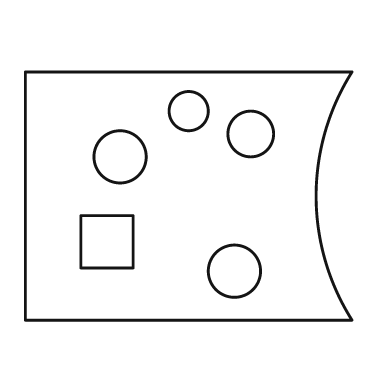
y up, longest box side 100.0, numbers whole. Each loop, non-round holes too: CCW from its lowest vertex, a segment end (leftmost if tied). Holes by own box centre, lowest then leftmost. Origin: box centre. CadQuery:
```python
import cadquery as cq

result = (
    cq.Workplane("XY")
    .moveTo(-50.0, -38.0)
    .lineTo(50.0, -38.0)
    .threePointArc((39.0, 0.0), (50.0, 38.0))
    .lineTo(-50.0, 38.0)
    .close()
    .moveTo(14.0, -23.0)
    .circle(8.0)
    .moveTo(-33.0, -22.0)
    .lineTo(-17.0, -22.0)
    .lineTo(-17.0, -6.0)
    .lineTo(-33.0, -6.0)
    .close()
    .moveTo(-21.0, 12.0)
    .circle(8.0)
    .moveTo(19.0, 19.0)
    .circle(7.0)
    .moveTo(0.0, 26.0)
    .circle(6.0)
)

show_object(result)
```